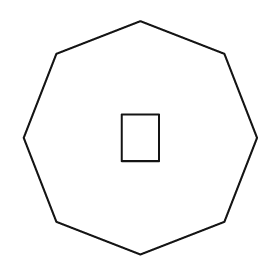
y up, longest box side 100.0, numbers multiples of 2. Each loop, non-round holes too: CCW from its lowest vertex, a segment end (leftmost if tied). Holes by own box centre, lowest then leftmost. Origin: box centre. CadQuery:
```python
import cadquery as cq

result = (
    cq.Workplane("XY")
    .moveTo(0.0, -50.0)
    .lineTo(36.0, -36.0)
    .lineTo(50.0, 0.0)
    .lineTo(36.0, 36.0)
    .lineTo(0.0, 50.0)
    .lineTo(-36.0, 36.0)
    .lineTo(-50.0, 0.0)
    .lineTo(-36.0, -36.0)
    .close()
    .moveTo(-8.0, -10.0)
    .lineTo(8.0, -10.0)
    .lineTo(8.0, 10.0)
    .lineTo(-8.0, 10.0)
    .close()
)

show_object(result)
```